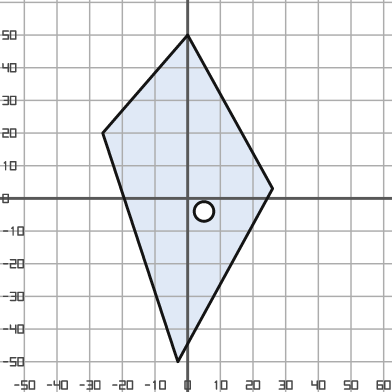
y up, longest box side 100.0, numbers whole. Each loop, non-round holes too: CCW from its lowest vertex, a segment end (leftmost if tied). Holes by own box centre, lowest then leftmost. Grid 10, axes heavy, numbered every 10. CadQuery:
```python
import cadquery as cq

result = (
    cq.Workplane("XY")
    .moveTo(-3.0, -50.0)
    .lineTo(26.0, 3.0)
    .lineTo(0.0, 50.0)
    .lineTo(-26.0, 20.0)
    .close()
    .moveTo(5.0, -4.0)
    .circle(3.0)
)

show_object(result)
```